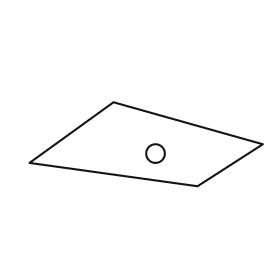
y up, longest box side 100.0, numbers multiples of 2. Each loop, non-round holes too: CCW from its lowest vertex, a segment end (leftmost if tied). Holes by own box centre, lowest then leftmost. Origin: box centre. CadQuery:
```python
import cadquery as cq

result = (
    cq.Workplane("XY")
    .moveTo(22.0, -18.0)
    .lineTo(50.0, 0.0)
    .lineTo(-14.0, 18.0)
    .lineTo(-50.0, -8.0)
    .close()
    .moveTo(4.0, -4.0)
    .circle(4.0)
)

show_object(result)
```